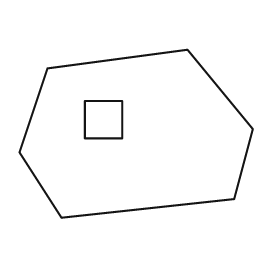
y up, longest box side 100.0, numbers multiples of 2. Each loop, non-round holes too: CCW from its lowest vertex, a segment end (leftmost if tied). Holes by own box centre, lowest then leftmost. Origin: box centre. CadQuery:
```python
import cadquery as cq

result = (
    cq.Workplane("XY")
    .moveTo(-32.0, -36.0)
    .lineTo(42.0, -28.0)
    .lineTo(50.0, 2.0)
    .lineTo(22.0, 36.0)
    .lineTo(-38.0, 28.0)
    .lineTo(-50.0, -8.0)
    .close()
    .moveTo(-22.0, -2.0)
    .lineTo(-6.0, -2.0)
    .lineTo(-6.0, 14.0)
    .lineTo(-22.0, 14.0)
    .close()
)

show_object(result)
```